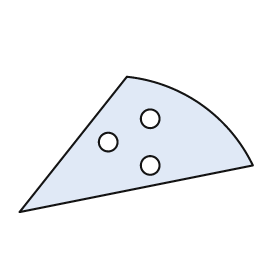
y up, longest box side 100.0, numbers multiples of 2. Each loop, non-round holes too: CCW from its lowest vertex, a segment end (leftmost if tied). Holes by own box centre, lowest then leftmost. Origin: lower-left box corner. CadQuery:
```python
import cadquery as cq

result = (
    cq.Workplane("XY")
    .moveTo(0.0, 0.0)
    .lineTo(100.0, 20.0)
    .threePointArc((78.0, 46.0), (46.0, 58.0))
    .close()
    .moveTo(56.0, 20.0)
    .circle(4.0)
    .moveTo(38.0, 30.0)
    .circle(4.0)
    .moveTo(56.0, 40.0)
    .circle(4.0)
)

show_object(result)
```